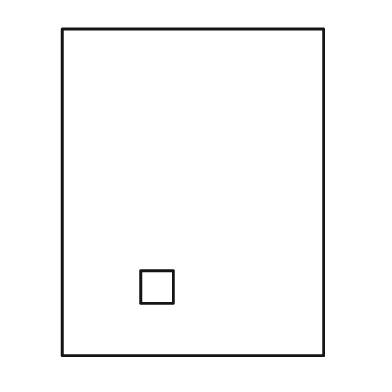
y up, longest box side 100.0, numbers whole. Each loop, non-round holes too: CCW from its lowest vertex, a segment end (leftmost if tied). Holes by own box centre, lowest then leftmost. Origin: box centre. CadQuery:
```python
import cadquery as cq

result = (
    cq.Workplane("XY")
    .moveTo(-40.0, -50.0)
    .lineTo(40.0, -50.0)
    .lineTo(40.0, 50.0)
    .lineTo(-40.0, 50.0)
    .close()
    .moveTo(-16.0, -34.0)
    .lineTo(-6.0, -34.0)
    .lineTo(-6.0, -24.0)
    .lineTo(-16.0, -24.0)
    .close()
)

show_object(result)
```